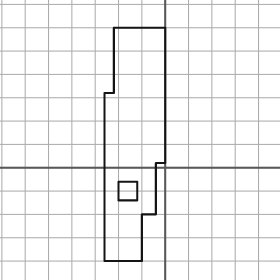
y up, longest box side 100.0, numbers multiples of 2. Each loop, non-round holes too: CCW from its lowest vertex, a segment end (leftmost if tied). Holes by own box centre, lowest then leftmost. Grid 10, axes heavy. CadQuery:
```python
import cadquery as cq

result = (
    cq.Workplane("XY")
    .moveTo(-26.0, -40.0)
    .lineTo(-10.0, -40.0)
    .lineTo(-10.0, -20.0)
    .lineTo(-4.0, -20.0)
    .lineTo(-4.0, 2.0)
    .lineTo(0.0, 2.0)
    .lineTo(0.0, 60.0)
    .lineTo(-22.0, 60.0)
    .lineTo(-22.0, 32.0)
    .lineTo(-26.0, 32.0)
    .close()
    .moveTo(-20.0, -14.0)
    .lineTo(-12.0, -14.0)
    .lineTo(-12.0, -6.0)
    .lineTo(-20.0, -6.0)
    .close()
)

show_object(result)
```